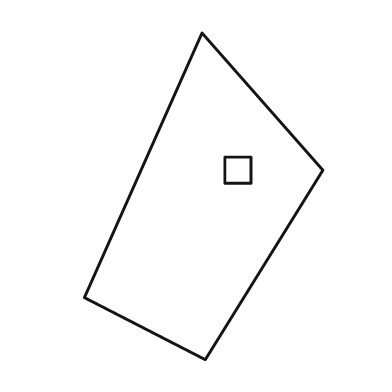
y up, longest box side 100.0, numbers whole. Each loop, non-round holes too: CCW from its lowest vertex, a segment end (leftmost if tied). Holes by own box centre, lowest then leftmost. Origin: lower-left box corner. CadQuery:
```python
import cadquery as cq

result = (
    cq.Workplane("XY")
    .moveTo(37.0, 0.0)
    .lineTo(73.0, 58.0)
    .lineTo(36.0, 100.0)
    .lineTo(0.0, 19.0)
    .close()
    .moveTo(43.0, 54.0)
    .lineTo(51.0, 54.0)
    .lineTo(51.0, 62.0)
    .lineTo(43.0, 62.0)
    .close()
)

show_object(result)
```